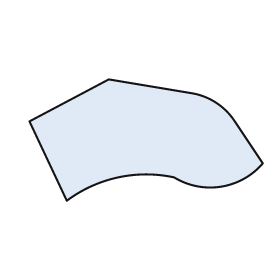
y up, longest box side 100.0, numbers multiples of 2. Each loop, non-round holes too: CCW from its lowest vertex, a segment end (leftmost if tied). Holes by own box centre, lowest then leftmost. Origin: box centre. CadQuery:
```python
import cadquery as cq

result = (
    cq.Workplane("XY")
    .moveTo(-34.0, -26.0)
    .threePointArc((-12.0, -16.0), (12.0, -16.0))
    .threePointArc((32.0, -20.0), (50.0, -10.0))
    .lineTo(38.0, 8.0)
    .threePointArc((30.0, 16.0), (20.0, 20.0))
    .lineTo(-16.0, 26.0)
    .lineTo(-50.0, 8.0)
    .close()
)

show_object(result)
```